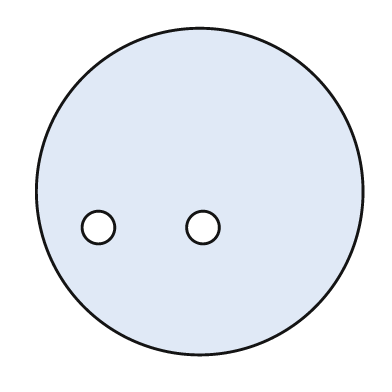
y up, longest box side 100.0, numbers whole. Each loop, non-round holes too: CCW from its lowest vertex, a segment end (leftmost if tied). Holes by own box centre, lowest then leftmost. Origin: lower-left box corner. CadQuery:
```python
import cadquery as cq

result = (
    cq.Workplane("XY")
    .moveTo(50.0, 50.0)
    .circle(50.0)
    .moveTo(19.0, 39.0)
    .circle(5.0)
    .moveTo(51.0, 39.0)
    .circle(5.0)
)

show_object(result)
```